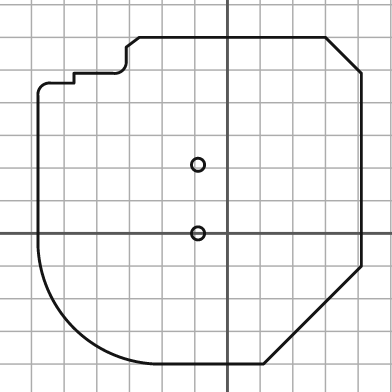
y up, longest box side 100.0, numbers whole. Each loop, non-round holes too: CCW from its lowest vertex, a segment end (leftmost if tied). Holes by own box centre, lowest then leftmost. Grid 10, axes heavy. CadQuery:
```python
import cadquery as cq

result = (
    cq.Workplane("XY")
    .moveTo(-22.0, -40.0)
    .lineTo(11.0, -40.0)
    .lineTo(41.0, -10.0)
    .lineTo(41.0, 49.0)
    .lineTo(30.0, 60.0)
    .lineTo(-27.0, 60.0)
    .lineTo(-31.0, 57.0)
    .lineTo(-31.0, 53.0)
    .threePointArc((-32.0, 50.0), (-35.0, 49.0))
    .lineTo(-47.0, 49.0)
    .lineTo(-47.0, 46.0)
    .lineTo(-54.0, 46.0)
    .threePointArc((-57.0, 45.0), (-58.0, 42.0))
    .lineTo(-58.0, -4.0)
    .threePointArc((-47.0, -29.0), (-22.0, -40.0))
    .close()
    .moveTo(-9.0, 0.0)
    .circle(2.0)
    .moveTo(-9.0, 21.0)
    .circle(2.0)
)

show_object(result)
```